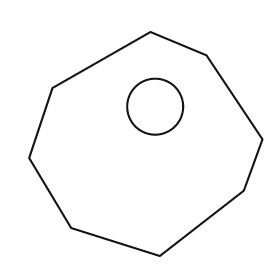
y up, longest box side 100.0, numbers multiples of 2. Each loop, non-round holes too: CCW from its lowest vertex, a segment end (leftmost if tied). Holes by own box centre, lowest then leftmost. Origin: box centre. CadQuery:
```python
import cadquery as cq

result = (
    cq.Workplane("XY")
    .moveTo(6.0, -48.0)
    .lineTo(42.0, -20.0)
    .lineTo(50.0, 2.0)
    .lineTo(26.0, 38.0)
    .lineTo(2.0, 48.0)
    .lineTo(-40.0, 24.0)
    .lineTo(-50.0, -6.0)
    .lineTo(-32.0, -36.0)
    .close()
    .moveTo(4.0, 16.0)
    .circle(12.0)
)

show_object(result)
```